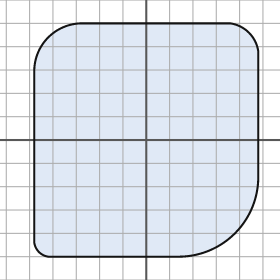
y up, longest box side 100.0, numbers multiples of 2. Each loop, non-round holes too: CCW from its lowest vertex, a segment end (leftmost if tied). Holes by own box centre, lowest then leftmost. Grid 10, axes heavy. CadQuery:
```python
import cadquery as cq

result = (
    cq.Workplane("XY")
    .moveTo(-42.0, -50.0)
    .lineTo(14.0, -50.0)
    .threePointArc((38.0, -40.0), (48.0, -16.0))
    .lineTo(48.0, 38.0)
    .threePointArc((44.0, 46.0), (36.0, 50.0))
    .lineTo(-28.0, 50.0)
    .threePointArc((-42.0, 44.0), (-48.0, 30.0))
    .lineTo(-48.0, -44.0)
    .threePointArc((-46.0, -48.0), (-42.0, -50.0))
    .close()
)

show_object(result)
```